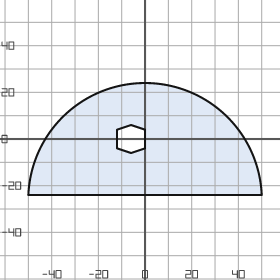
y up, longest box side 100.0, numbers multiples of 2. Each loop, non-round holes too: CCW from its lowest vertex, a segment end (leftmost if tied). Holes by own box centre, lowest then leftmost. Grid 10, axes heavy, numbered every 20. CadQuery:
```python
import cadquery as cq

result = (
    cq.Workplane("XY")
    .moveTo(-50.0, -24.0)
    .lineTo(50.0, -24.0)
    .threePointArc((0.0, 24.0), (-50.0, -24.0))
    .close()
    .moveTo(-6.0, -6.0)
    .lineTo(0.0, -4.0)
    .lineTo(0.0, 4.0)
    .lineTo(-6.0, 6.0)
    .lineTo(-12.0, 4.0)
    .lineTo(-12.0, -4.0)
    .close()
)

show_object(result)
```